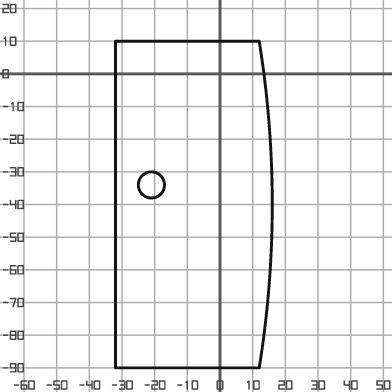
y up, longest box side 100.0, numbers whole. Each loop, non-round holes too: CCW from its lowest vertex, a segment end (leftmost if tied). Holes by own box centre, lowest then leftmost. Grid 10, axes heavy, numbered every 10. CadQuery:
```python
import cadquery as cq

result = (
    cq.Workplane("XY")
    .moveTo(-32.0, -90.0)
    .lineTo(12.0, -90.0)
    .threePointArc((16.0, -40.0), (12.0, 10.0))
    .lineTo(-32.0, 10.0)
    .close()
    .moveTo(-21.0, -34.0)
    .circle(4.0)
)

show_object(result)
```